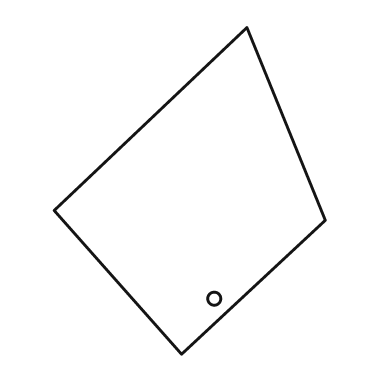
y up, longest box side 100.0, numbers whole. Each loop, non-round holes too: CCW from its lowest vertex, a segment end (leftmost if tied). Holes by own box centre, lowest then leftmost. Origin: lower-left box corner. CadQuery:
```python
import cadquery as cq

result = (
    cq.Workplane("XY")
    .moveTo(39.0, 0.0)
    .lineTo(83.0, 41.0)
    .lineTo(59.0, 100.0)
    .lineTo(0.0, 44.0)
    .close()
    .moveTo(49.0, 17.0)
    .circle(2.0)
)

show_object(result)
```